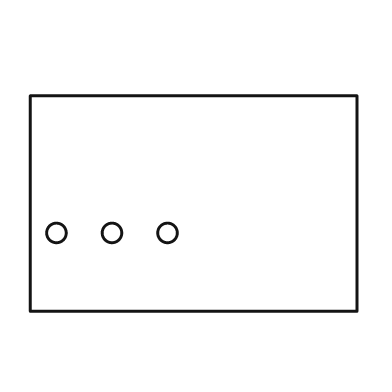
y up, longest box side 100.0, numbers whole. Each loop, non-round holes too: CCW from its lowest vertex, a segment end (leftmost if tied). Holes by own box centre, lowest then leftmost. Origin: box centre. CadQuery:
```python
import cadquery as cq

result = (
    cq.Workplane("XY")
    .moveTo(-50.0, -33.0)
    .lineTo(50.0, -33.0)
    .lineTo(50.0, 33.0)
    .lineTo(-50.0, 33.0)
    .close()
    .moveTo(-42.0, -9.0)
    .circle(3.0)
    .moveTo(-25.0, -9.0)
    .circle(3.0)
    .moveTo(-8.0, -9.0)
    .circle(3.0)
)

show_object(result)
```